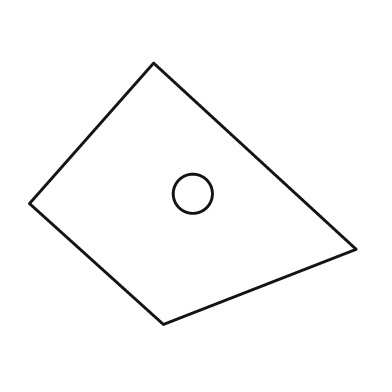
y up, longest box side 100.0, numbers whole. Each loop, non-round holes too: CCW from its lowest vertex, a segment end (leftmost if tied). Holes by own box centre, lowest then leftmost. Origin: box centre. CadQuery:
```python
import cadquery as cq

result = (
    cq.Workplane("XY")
    .moveTo(-9.0, -40.0)
    .lineTo(50.0, -17.0)
    .lineTo(-12.0, 40.0)
    .lineTo(-50.0, -3.0)
    .close()
    .moveTo(0.0, 0.0)
    .circle(6.0)
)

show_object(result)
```